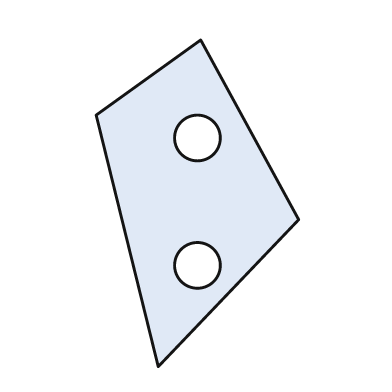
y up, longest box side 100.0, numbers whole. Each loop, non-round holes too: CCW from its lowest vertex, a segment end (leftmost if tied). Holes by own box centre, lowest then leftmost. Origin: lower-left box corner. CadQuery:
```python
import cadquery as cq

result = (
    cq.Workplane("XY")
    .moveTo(19.0, 0.0)
    .lineTo(62.0, 45.0)
    .lineTo(32.0, 100.0)
    .lineTo(0.0, 77.0)
    .close()
    .moveTo(31.0, 31.0)
    .circle(7.0)
    .moveTo(31.0, 70.0)
    .circle(7.0)
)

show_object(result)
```